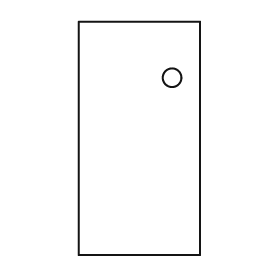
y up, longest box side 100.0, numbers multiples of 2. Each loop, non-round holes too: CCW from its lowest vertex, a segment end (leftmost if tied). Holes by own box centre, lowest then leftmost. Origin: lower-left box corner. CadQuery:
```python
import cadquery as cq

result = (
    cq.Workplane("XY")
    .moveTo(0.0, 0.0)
    .lineTo(52.0, 0.0)
    .lineTo(52.0, 100.0)
    .lineTo(0.0, 100.0)
    .close()
    .moveTo(40.0, 76.0)
    .circle(4.0)
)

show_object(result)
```